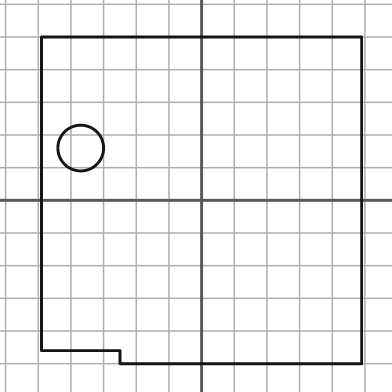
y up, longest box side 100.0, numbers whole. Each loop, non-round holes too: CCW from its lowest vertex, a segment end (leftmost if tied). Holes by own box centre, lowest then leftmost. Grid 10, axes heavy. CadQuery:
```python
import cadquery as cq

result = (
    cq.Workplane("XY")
    .moveTo(-25.0, -50.0)
    .lineTo(49.0, -50.0)
    .lineTo(49.0, 50.0)
    .lineTo(-49.0, 50.0)
    .lineTo(-49.0, -46.0)
    .lineTo(-25.0, -46.0)
    .close()
    .moveTo(-37.0, 16.0)
    .circle(7.0)
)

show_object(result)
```